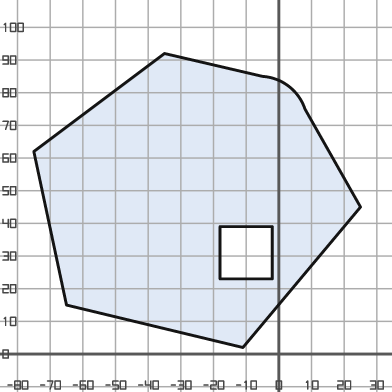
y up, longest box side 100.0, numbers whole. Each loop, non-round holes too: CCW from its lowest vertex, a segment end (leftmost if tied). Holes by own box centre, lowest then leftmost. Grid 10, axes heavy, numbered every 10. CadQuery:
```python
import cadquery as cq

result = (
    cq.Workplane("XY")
    .moveTo(-11.0, 2.0)
    .lineTo(25.0, 45.0)
    .lineTo(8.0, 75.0)
    .threePointArc((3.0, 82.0), (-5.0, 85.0))
    .lineTo(-35.0, 92.0)
    .lineTo(-75.0, 62.0)
    .lineTo(-65.0, 15.0)
    .close()
    .moveTo(-18.0, 23.0)
    .lineTo(-2.0, 23.0)
    .lineTo(-2.0, 39.0)
    .lineTo(-18.0, 39.0)
    .close()
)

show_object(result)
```